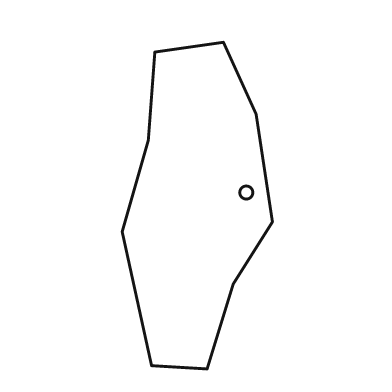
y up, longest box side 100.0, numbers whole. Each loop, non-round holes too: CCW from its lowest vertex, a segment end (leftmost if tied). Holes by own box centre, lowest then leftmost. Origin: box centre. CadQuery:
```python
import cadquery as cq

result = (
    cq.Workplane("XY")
    .moveTo(3.0, -50.0)
    .lineTo(11.0, -24.0)
    .lineTo(23.0, -5.0)
    .lineTo(18.0, 28.0)
    .lineTo(8.0, 50.0)
    .lineTo(-13.0, 47.0)
    .lineTo(-15.0, 20.0)
    .lineTo(-23.0, -8.0)
    .lineTo(-14.0, -49.0)
    .close()
    .moveTo(15.0, 4.0)
    .circle(2.0)
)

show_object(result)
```